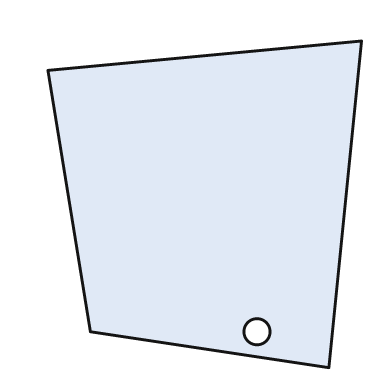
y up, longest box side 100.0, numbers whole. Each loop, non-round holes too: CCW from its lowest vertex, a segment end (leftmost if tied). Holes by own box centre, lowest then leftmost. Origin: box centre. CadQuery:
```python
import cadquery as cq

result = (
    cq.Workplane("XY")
    .moveTo(38.0, -50.0)
    .lineTo(48.0, 50.0)
    .lineTo(-48.0, 41.0)
    .lineTo(-35.0, -39.0)
    .close()
    .moveTo(16.0, -39.0)
    .circle(4.0)
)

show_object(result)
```